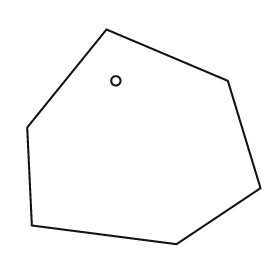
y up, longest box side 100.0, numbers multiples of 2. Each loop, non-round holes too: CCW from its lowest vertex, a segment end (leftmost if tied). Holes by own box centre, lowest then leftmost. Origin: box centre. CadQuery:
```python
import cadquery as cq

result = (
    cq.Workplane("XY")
    .moveTo(14.0, -46.0)
    .lineTo(50.0, -22.0)
    .lineTo(36.0, 24.0)
    .lineTo(-16.0, 46.0)
    .lineTo(-50.0, 4.0)
    .lineTo(-48.0, -38.0)
    .close()
    .moveTo(-12.0, 24.0)
    .circle(2.0)
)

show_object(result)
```